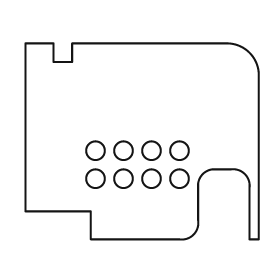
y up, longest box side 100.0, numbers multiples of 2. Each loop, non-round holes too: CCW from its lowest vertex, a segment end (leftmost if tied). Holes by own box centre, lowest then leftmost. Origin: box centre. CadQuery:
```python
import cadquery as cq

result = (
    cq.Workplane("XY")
    .moveTo(-22.0, -42.0)
    .lineTo(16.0, -42.0)
    .threePointArc((22.0, -40.0), (24.0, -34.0))
    .lineTo(24.0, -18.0)
    .threePointArc((26.0, -14.0), (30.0, -12.0))
    .lineTo(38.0, -12.0)
    .threePointArc((44.0, -14.0), (46.0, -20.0))
    .lineTo(46.0, -42.0)
    .lineTo(50.0, -42.0)
    .lineTo(50.0, 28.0)
    .threePointArc((46.0, 38.0), (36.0, 42.0))
    .lineTo(-30.0, 42.0)
    .lineTo(-30.0, 34.0)
    .lineTo(-38.0, 34.0)
    .lineTo(-38.0, 42.0)
    .lineTo(-50.0, 42.0)
    .lineTo(-50.0, -30.0)
    .lineTo(-22.0, -30.0)
    .close()
    .moveTo(-20.0, -16.0)
    .circle(4.0)
    .moveTo(-8.0, -16.0)
    .circle(4.0)
    .moveTo(4.0, -16.0)
    .circle(4.0)
    .moveTo(16.0, -16.0)
    .circle(4.0)
    .moveTo(-20.0, -4.0)
    .circle(4.0)
    .moveTo(-8.0, -4.0)
    .circle(4.0)
    .moveTo(4.0, -4.0)
    .circle(4.0)
    .moveTo(16.0, -4.0)
    .circle(4.0)
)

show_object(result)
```